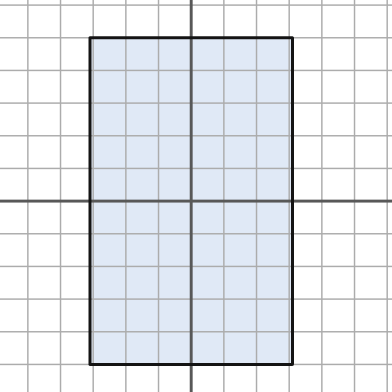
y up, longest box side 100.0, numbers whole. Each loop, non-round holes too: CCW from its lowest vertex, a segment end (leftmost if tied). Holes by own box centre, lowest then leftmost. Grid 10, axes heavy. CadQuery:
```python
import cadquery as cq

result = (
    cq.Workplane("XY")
    .moveTo(-31.0, -50.0)
    .lineTo(31.0, -50.0)
    .lineTo(31.0, 50.0)
    .lineTo(-31.0, 50.0)
    .close()
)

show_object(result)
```